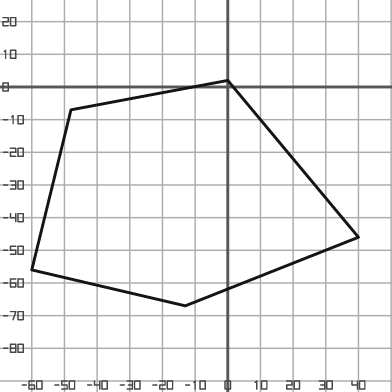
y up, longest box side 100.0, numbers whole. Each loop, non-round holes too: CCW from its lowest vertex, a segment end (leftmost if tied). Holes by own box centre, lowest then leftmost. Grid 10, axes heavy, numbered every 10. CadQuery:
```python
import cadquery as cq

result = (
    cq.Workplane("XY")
    .moveTo(-13.0, -67.0)
    .lineTo(40.0, -46.0)
    .lineTo(0.0, 2.0)
    .lineTo(-48.0, -7.0)
    .lineTo(-60.0, -56.0)
    .close()
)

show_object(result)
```